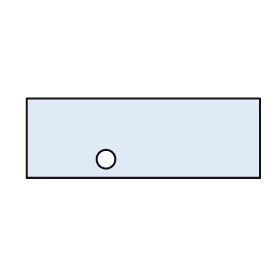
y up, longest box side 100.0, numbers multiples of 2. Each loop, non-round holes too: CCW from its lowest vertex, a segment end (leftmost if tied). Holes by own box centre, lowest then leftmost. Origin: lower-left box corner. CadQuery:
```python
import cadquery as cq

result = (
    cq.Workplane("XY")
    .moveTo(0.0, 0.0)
    .lineTo(100.0, 0.0)
    .lineTo(100.0, 34.0)
    .lineTo(0.0, 34.0)
    .close()
    .moveTo(34.0, 8.0)
    .circle(4.0)
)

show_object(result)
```